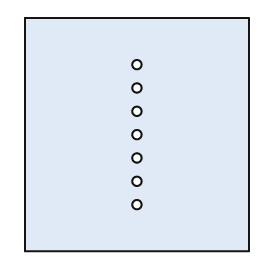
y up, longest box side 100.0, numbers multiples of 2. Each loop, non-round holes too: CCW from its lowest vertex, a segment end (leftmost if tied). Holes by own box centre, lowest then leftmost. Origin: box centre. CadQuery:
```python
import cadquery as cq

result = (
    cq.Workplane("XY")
    .moveTo(-48.0, -50.0)
    .lineTo(48.0, -50.0)
    .lineTo(48.0, 50.0)
    .lineTo(-48.0, 50.0)
    .close()
    .moveTo(0.0, -30.0)
    .circle(2.0)
    .moveTo(0.0, -20.0)
    .circle(2.0)
    .moveTo(0.0, -10.0)
    .circle(2.0)
    .moveTo(0.0, 0.0)
    .circle(2.0)
    .moveTo(0.0, 10.0)
    .circle(2.0)
    .moveTo(0.0, 20.0)
    .circle(2.0)
    .moveTo(0.0, 30.0)
    .circle(2.0)
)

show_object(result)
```